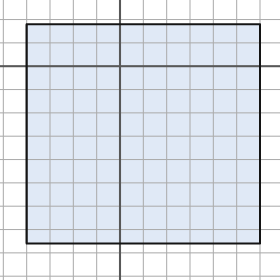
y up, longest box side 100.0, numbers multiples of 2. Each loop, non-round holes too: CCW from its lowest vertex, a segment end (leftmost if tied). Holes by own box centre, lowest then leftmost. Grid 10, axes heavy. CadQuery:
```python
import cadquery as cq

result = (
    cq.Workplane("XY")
    .moveTo(-40.0, -76.0)
    .lineTo(60.0, -76.0)
    .lineTo(60.0, 18.0)
    .lineTo(-40.0, 18.0)
    .close()
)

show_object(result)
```